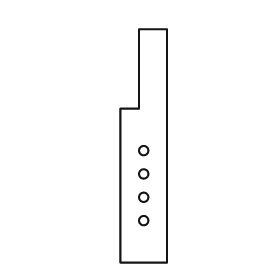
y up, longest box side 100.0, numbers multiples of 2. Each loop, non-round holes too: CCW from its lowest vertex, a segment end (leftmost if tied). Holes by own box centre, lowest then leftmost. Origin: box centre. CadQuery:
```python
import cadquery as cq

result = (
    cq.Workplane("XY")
    .moveTo(-10.0, -50.0)
    .lineTo(10.0, -50.0)
    .lineTo(10.0, 50.0)
    .lineTo(-2.0, 50.0)
    .lineTo(-2.0, 16.0)
    .lineTo(-10.0, 16.0)
    .close()
    .moveTo(0.0, -32.0)
    .circle(2.0)
    .moveTo(0.0, -22.0)
    .circle(2.0)
    .moveTo(0.0, -12.0)
    .circle(2.0)
    .moveTo(0.0, -2.0)
    .circle(2.0)
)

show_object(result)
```